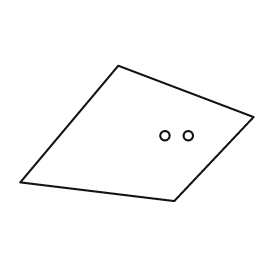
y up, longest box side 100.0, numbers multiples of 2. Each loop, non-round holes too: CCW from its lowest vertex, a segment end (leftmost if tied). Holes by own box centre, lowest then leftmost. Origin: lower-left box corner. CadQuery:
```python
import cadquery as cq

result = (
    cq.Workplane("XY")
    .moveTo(66.0, 0.0)
    .lineTo(100.0, 36.0)
    .lineTo(42.0, 58.0)
    .lineTo(0.0, 8.0)
    .close()
    .moveTo(62.0, 28.0)
    .circle(2.0)
    .moveTo(72.0, 28.0)
    .circle(2.0)
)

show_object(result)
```